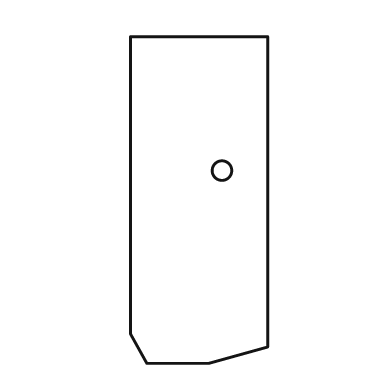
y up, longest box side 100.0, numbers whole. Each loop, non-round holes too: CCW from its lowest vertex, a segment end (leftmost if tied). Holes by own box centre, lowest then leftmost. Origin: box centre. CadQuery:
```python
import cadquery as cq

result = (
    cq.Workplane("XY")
    .moveTo(-16.0, -50.0)
    .lineTo(3.0, -50.0)
    .lineTo(21.0, -45.0)
    .lineTo(21.0, 50.0)
    .lineTo(-21.0, 50.0)
    .lineTo(-21.0, -41.0)
    .close()
    .moveTo(7.0, 9.0)
    .circle(3.0)
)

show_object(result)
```